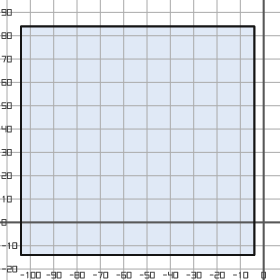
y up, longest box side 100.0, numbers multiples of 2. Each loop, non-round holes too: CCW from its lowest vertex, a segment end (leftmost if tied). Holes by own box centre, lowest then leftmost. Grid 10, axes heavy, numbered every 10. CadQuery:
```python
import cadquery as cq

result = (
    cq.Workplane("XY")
    .moveTo(-104.0, -14.0)
    .lineTo(-4.0, -14.0)
    .lineTo(-4.0, 84.0)
    .lineTo(-104.0, 84.0)
    .close()
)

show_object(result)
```